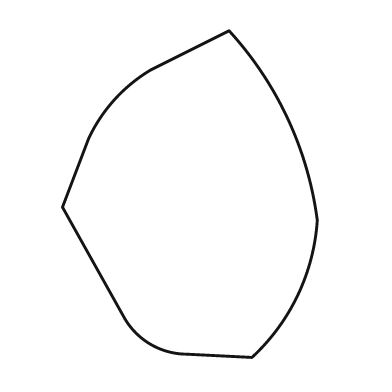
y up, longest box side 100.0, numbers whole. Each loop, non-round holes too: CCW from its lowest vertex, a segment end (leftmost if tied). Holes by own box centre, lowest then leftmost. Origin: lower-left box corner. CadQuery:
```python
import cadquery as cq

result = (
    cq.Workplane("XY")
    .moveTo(58.0, 0.0)
    .threePointArc((72.0, 19.0), (78.0, 42.0))
    .threePointArc((69.0, 73.0), (51.0, 100.0))
    .lineTo(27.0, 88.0)
    .threePointArc((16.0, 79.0), (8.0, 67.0))
    .lineTo(0.0, 46.0)
    .lineTo(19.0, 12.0)
    .threePointArc((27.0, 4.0), (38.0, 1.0))
    .close()
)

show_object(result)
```